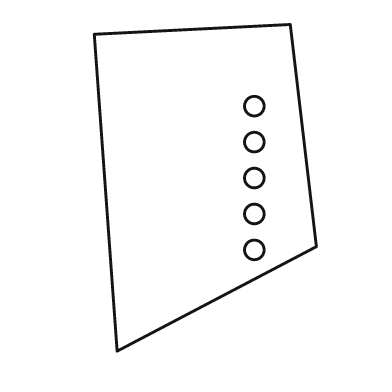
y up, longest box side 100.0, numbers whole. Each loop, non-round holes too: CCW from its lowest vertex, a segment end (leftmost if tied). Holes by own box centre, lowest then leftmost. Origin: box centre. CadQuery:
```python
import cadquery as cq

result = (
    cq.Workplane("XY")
    .moveTo(-27.0, -50.0)
    .lineTo(34.0, -18.0)
    .lineTo(26.0, 50.0)
    .lineTo(-34.0, 47.0)
    .close()
    .moveTo(15.0, -19.0)
    .circle(3.0)
    .moveTo(15.0, -8.0)
    .circle(3.0)
    .moveTo(15.0, 3.0)
    .circle(3.0)
    .moveTo(15.0, 14.0)
    .circle(3.0)
    .moveTo(15.0, 25.0)
    .circle(3.0)
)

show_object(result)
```